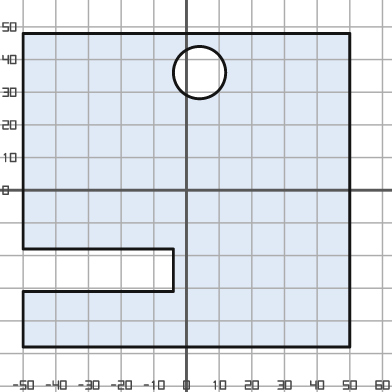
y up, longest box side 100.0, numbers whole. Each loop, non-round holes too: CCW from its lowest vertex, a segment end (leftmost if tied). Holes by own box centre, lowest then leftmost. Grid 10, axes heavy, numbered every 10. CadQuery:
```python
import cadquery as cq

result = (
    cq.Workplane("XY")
    .moveTo(-50.0, -48.0)
    .lineTo(50.0, -48.0)
    .lineTo(50.0, 48.0)
    .lineTo(-50.0, 48.0)
    .lineTo(-50.0, -18.0)
    .lineTo(-4.0, -18.0)
    .lineTo(-4.0, -31.0)
    .lineTo(-50.0, -31.0)
    .close()
    .moveTo(4.0, 36.0)
    .circle(8.0)
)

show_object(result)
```